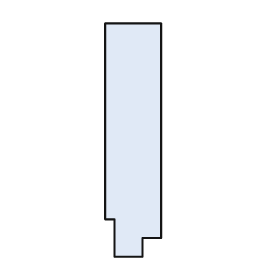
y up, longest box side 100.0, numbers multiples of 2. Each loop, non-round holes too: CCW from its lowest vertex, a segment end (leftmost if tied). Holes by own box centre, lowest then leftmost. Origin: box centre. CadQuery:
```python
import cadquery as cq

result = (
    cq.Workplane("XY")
    .moveTo(-8.0, -50.0)
    .lineTo(4.0, -50.0)
    .lineTo(4.0, -42.0)
    .lineTo(12.0, -42.0)
    .lineTo(12.0, 50.0)
    .lineTo(-12.0, 50.0)
    .lineTo(-12.0, -34.0)
    .lineTo(-8.0, -34.0)
    .close()
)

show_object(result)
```